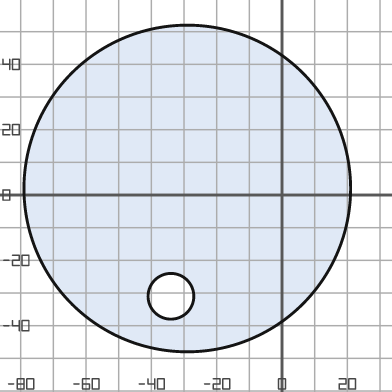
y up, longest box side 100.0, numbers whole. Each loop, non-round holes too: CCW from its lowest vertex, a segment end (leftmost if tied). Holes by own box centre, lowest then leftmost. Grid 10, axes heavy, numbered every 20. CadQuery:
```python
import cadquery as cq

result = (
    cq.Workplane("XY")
    .moveTo(-29.0, 2.0)
    .circle(50.0)
    .moveTo(-34.0, -31.0)
    .circle(7.0)
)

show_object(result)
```